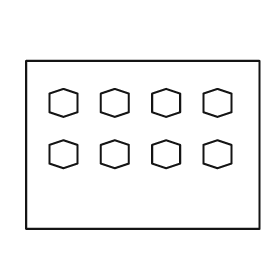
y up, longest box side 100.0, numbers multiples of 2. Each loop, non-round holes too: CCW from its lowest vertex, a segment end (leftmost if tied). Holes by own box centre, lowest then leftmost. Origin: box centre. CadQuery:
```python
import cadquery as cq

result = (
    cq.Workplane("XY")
    .moveTo(-50.0, -36.0)
    .lineTo(50.0, -36.0)
    .lineTo(50.0, 36.0)
    .lineTo(-50.0, 36.0)
    .close()
    .moveTo(-34.0, -10.0)
    .lineTo(-28.0, -8.0)
    .lineTo(-28.0, 0.0)
    .lineTo(-34.0, 2.0)
    .lineTo(-40.0, 0.0)
    .lineTo(-40.0, -8.0)
    .close()
    .moveTo(-12.0, -10.0)
    .lineTo(-6.0, -8.0)
    .lineTo(-6.0, 0.0)
    .lineTo(-12.0, 2.0)
    .lineTo(-18.0, 0.0)
    .lineTo(-18.0, -8.0)
    .close()
    .moveTo(10.0, -10.0)
    .lineTo(16.0, -8.0)
    .lineTo(16.0, 0.0)
    .lineTo(10.0, 2.0)
    .lineTo(4.0, 0.0)
    .lineTo(4.0, -8.0)
    .close()
    .moveTo(32.0, -10.0)
    .lineTo(38.0, -8.0)
    .lineTo(38.0, 0.0)
    .lineTo(32.0, 2.0)
    .lineTo(26.0, 0.0)
    .lineTo(26.0, -8.0)
    .close()
    .moveTo(-34.0, 12.0)
    .lineTo(-28.0, 14.0)
    .lineTo(-28.0, 22.0)
    .lineTo(-34.0, 24.0)
    .lineTo(-40.0, 22.0)
    .lineTo(-40.0, 14.0)
    .close()
    .moveTo(-12.0, 12.0)
    .lineTo(-6.0, 14.0)
    .lineTo(-6.0, 22.0)
    .lineTo(-12.0, 24.0)
    .lineTo(-18.0, 22.0)
    .lineTo(-18.0, 14.0)
    .close()
    .moveTo(10.0, 12.0)
    .lineTo(16.0, 14.0)
    .lineTo(16.0, 22.0)
    .lineTo(10.0, 24.0)
    .lineTo(4.0, 22.0)
    .lineTo(4.0, 14.0)
    .close()
    .moveTo(32.0, 12.0)
    .lineTo(38.0, 14.0)
    .lineTo(38.0, 22.0)
    .lineTo(32.0, 24.0)
    .lineTo(26.0, 22.0)
    .lineTo(26.0, 14.0)
    .close()
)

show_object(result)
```